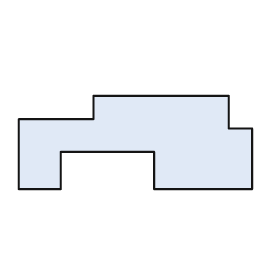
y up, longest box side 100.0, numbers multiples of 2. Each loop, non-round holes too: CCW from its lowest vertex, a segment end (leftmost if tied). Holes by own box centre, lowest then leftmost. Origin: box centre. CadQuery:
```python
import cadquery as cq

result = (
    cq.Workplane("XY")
    .moveTo(-50.0, -20.0)
    .lineTo(-32.0, -20.0)
    .lineTo(-32.0, -4.0)
    .lineTo(8.0, -4.0)
    .lineTo(8.0, -20.0)
    .lineTo(50.0, -20.0)
    .lineTo(50.0, 6.0)
    .lineTo(40.0, 6.0)
    .lineTo(40.0, 20.0)
    .lineTo(-18.0, 20.0)
    .lineTo(-18.0, 10.0)
    .lineTo(-50.0, 10.0)
    .close()
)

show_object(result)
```